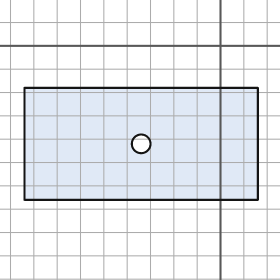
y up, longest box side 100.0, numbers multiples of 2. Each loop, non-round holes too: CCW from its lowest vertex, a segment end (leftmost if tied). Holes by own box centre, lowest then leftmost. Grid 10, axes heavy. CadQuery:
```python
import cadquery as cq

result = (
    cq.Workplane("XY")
    .moveTo(-84.0, -66.0)
    .lineTo(16.0, -66.0)
    .lineTo(16.0, -18.0)
    .lineTo(-84.0, -18.0)
    .close()
    .moveTo(-34.0, -42.0)
    .circle(4.0)
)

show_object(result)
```